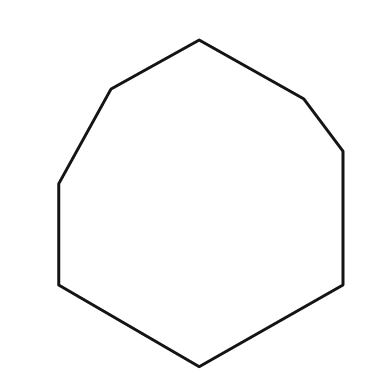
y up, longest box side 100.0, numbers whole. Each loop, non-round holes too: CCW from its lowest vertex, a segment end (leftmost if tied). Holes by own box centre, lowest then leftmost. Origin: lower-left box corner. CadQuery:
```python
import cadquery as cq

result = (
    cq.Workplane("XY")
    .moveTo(43.0, 0.0)
    .lineTo(87.0, 25.0)
    .lineTo(87.0, 66.0)
    .lineTo(75.0, 82.0)
    .lineTo(43.0, 100.0)
    .lineTo(16.0, 85.0)
    .lineTo(0.0, 56.0)
    .lineTo(0.0, 25.0)
    .close()
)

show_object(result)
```